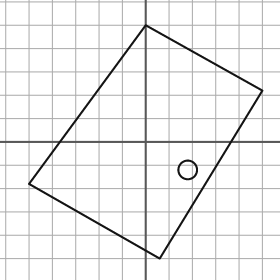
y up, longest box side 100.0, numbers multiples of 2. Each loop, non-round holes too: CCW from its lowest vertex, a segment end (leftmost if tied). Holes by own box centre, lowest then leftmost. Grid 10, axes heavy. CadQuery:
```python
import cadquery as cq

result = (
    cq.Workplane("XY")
    .moveTo(6.0, -50.0)
    .lineTo(50.0, 22.0)
    .lineTo(0.0, 50.0)
    .lineTo(-50.0, -18.0)
    .close()
    .moveTo(18.0, -12.0)
    .circle(4.0)
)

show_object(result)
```